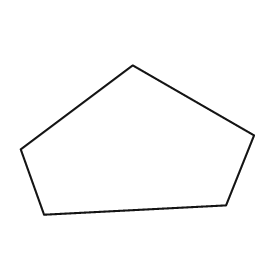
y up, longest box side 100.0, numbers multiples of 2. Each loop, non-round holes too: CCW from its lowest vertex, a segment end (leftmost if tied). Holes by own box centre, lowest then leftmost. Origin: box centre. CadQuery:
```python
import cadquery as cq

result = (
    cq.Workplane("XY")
    .moveTo(-40.0, -32.0)
    .lineTo(38.0, -28.0)
    .lineTo(50.0, 2.0)
    .lineTo(-2.0, 32.0)
    .lineTo(-50.0, -4.0)
    .close()
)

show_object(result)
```